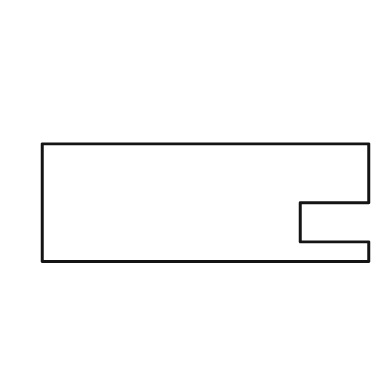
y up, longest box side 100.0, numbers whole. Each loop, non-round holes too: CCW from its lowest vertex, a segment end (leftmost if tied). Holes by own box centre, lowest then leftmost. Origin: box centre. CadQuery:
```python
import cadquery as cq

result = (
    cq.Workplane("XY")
    .moveTo(-50.0, -18.0)
    .lineTo(50.0, -18.0)
    .lineTo(50.0, -12.0)
    .lineTo(29.0, -12.0)
    .lineTo(29.0, 0.0)
    .lineTo(50.0, 0.0)
    .lineTo(50.0, 18.0)
    .lineTo(-50.0, 18.0)
    .close()
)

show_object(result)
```